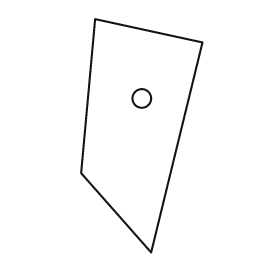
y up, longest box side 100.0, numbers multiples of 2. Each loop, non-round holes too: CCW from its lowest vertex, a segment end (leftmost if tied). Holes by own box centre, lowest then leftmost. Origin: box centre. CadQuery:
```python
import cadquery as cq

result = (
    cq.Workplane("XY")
    .moveTo(4.0, -50.0)
    .lineTo(26.0, 40.0)
    .lineTo(-20.0, 50.0)
    .lineTo(-26.0, -16.0)
    .close()
    .moveTo(0.0, 16.0)
    .circle(4.0)
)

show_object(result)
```